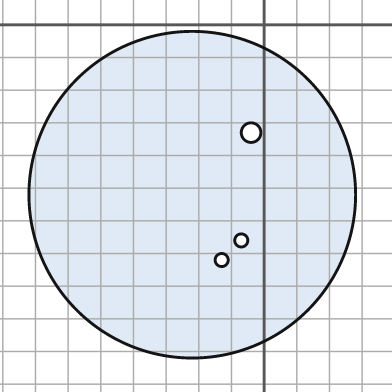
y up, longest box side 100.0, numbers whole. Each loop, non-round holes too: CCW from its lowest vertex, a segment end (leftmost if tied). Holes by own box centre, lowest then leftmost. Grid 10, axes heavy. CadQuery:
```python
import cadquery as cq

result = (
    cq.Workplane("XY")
    .moveTo(-22.0, -52.0)
    .circle(50.0)
    .moveTo(-13.0, -72.0)
    .circle(2.0)
    .moveTo(-7.0, -66.0)
    .circle(2.0)
    .moveTo(-4.0, -33.0)
    .circle(3.0)
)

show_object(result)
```